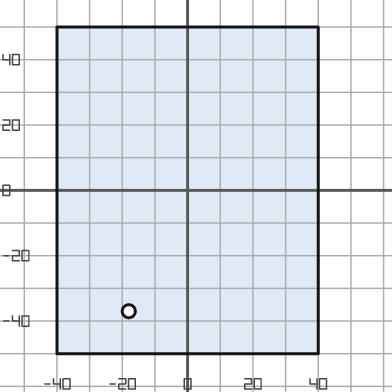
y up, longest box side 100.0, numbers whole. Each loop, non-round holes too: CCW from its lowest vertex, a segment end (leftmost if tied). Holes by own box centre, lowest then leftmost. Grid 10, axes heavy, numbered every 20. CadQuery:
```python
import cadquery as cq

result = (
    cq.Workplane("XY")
    .moveTo(-40.0, -50.0)
    .lineTo(40.0, -50.0)
    .lineTo(40.0, 50.0)
    .lineTo(-40.0, 50.0)
    .close()
    .moveTo(-18.0, -37.0)
    .circle(2.0)
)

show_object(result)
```